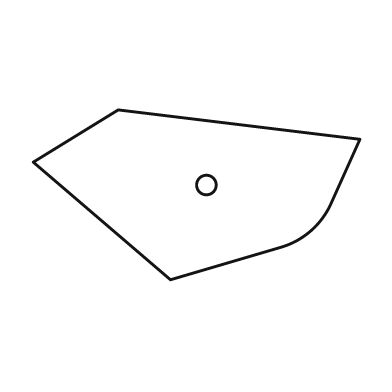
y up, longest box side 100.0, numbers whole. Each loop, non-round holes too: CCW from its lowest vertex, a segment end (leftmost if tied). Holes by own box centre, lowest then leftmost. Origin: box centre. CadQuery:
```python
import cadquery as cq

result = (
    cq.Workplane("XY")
    .moveTo(-8.0, -26.0)
    .lineTo(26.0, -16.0)
    .threePointArc((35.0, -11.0), (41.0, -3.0))
    .lineTo(50.0, 17.0)
    .lineTo(-24.0, 26.0)
    .lineTo(-50.0, 10.0)
    .close()
    .moveTo(3.0, 3.0)
    .circle(3.0)
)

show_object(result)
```